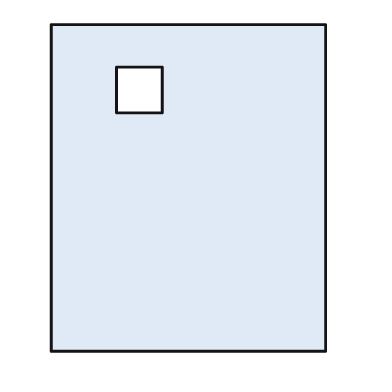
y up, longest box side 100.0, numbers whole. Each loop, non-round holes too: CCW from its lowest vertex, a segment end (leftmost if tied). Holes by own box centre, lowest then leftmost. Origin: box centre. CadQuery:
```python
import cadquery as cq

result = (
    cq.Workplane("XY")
    .moveTo(-42.0, -50.0)
    .lineTo(42.0, -50.0)
    .lineTo(42.0, 50.0)
    .lineTo(-42.0, 50.0)
    .close()
    .moveTo(-22.0, 23.0)
    .lineTo(-8.0, 23.0)
    .lineTo(-8.0, 37.0)
    .lineTo(-22.0, 37.0)
    .close()
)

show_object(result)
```